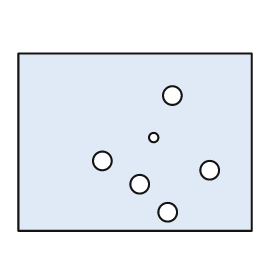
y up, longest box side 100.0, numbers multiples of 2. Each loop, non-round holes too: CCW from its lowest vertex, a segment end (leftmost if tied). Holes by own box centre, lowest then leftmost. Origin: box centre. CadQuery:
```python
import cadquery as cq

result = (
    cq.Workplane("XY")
    .moveTo(-50.0, -38.0)
    .lineTo(50.0, -38.0)
    .lineTo(50.0, 38.0)
    .lineTo(-50.0, 38.0)
    .close()
    .moveTo(14.0, -30.0)
    .circle(4.0)
    .moveTo(2.0, -18.0)
    .circle(4.0)
    .moveTo(32.0, -12.0)
    .circle(4.0)
    .moveTo(-14.0, -8.0)
    .circle(4.0)
    .moveTo(8.0, 2.0)
    .circle(2.0)
    .moveTo(16.0, 20.0)
    .circle(4.0)
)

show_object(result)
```